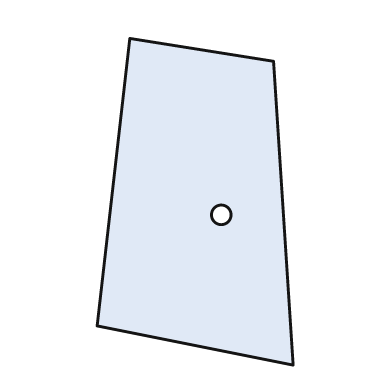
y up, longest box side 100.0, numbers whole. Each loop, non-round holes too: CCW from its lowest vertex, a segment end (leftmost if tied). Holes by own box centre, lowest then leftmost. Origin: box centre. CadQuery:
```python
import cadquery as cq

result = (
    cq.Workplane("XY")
    .moveTo(30.0, -50.0)
    .lineTo(24.0, 43.0)
    .lineTo(-20.0, 50.0)
    .lineTo(-30.0, -38.0)
    .close()
    .moveTo(8.0, -4.0)
    .circle(3.0)
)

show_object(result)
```